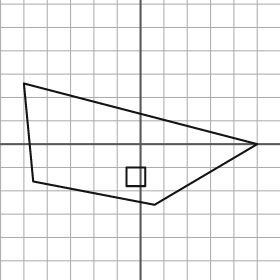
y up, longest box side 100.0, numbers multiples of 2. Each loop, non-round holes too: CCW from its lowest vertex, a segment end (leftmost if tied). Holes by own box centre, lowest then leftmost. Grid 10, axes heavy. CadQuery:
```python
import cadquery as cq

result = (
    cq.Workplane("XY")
    .moveTo(6.0, -26.0)
    .lineTo(50.0, 0.0)
    .lineTo(-50.0, 26.0)
    .lineTo(-46.0, -16.0)
    .close()
    .moveTo(-6.0, -18.0)
    .lineTo(2.0, -18.0)
    .lineTo(2.0, -10.0)
    .lineTo(-6.0, -10.0)
    .close()
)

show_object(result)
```